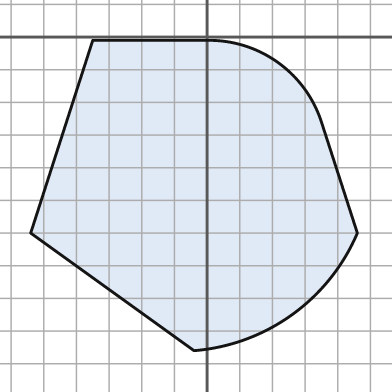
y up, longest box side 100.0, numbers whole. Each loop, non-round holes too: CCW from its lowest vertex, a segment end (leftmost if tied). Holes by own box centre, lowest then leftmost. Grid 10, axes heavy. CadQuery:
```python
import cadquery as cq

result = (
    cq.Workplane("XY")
    .moveTo(-4.0, -96.0)
    .threePointArc((26.0, -85.0), (46.0, -60.0))
    .lineTo(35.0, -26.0)
    .threePointArc((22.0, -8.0), (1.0, -1.0))
    .lineTo(-35.0, -1.0)
    .lineTo(-54.0, -60.0)
    .close()
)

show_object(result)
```